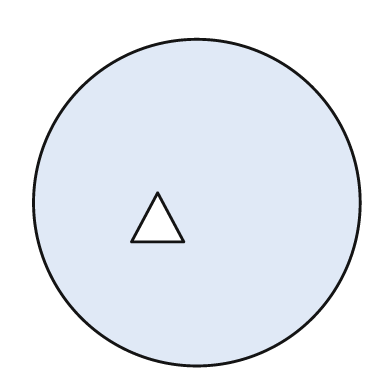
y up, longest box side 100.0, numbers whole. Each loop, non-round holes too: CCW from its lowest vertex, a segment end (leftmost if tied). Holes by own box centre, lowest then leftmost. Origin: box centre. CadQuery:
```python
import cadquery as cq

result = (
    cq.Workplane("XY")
    .moveTo(0.0, 0.0)
    .circle(50.0)
    .moveTo(-20.0, -12.0)
    .lineTo(-4.0, -12.0)
    .lineTo(-12.0, 3.0)
    .close()
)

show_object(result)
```